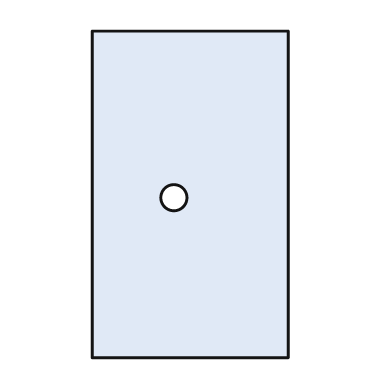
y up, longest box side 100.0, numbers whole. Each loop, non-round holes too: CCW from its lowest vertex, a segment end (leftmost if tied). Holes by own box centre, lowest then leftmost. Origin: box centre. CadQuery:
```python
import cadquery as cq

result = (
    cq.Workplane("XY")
    .moveTo(-30.0, -50.0)
    .lineTo(30.0, -50.0)
    .lineTo(30.0, 50.0)
    .lineTo(-30.0, 50.0)
    .close()
    .moveTo(-5.0, -1.0)
    .circle(4.0)
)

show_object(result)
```